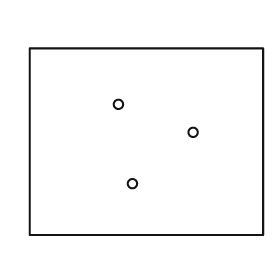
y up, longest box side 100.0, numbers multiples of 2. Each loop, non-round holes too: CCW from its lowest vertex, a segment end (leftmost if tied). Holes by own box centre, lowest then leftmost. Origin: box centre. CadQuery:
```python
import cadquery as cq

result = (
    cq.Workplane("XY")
    .moveTo(-50.0, -40.0)
    .lineTo(50.0, -40.0)
    .lineTo(50.0, 40.0)
    .lineTo(-50.0, 40.0)
    .close()
    .moveTo(-6.0, -18.0)
    .circle(2.0)
    .moveTo(20.0, 4.0)
    .circle(2.0)
    .moveTo(-12.0, 16.0)
    .circle(2.0)
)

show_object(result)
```